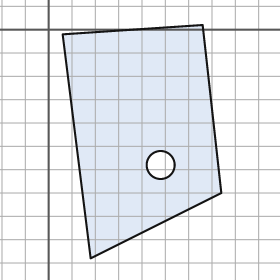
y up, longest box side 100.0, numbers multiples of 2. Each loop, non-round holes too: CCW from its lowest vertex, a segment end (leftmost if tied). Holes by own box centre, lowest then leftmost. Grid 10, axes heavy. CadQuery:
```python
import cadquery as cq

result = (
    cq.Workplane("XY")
    .moveTo(18.0, -98.0)
    .lineTo(74.0, -70.0)
    .lineTo(66.0, 2.0)
    .lineTo(6.0, -2.0)
    .close()
    .moveTo(48.0, -58.0)
    .circle(6.0)
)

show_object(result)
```